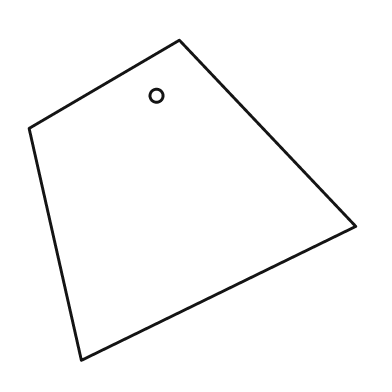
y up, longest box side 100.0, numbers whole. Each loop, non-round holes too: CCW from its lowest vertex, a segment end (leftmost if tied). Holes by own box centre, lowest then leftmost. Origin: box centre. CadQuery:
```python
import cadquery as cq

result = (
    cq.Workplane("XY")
    .moveTo(-34.0, -49.0)
    .lineTo(50.0, -8.0)
    .lineTo(-4.0, 49.0)
    .lineTo(-50.0, 22.0)
    .close()
    .moveTo(-11.0, 32.0)
    .circle(2.0)
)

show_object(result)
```